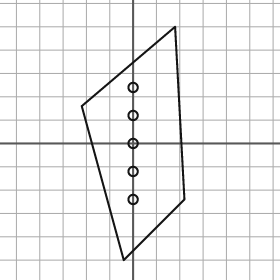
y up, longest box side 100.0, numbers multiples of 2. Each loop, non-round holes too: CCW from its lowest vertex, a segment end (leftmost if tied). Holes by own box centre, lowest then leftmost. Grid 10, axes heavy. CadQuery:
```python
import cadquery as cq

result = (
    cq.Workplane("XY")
    .moveTo(-4.0, -50.0)
    .lineTo(22.0, -24.0)
    .lineTo(18.0, 50.0)
    .lineTo(-22.0, 16.0)
    .close()
    .moveTo(0.0, -24.0)
    .circle(2.0)
    .moveTo(0.0, -12.0)
    .circle(2.0)
    .moveTo(0.0, 0.0)
    .circle(2.0)
    .moveTo(0.0, 12.0)
    .circle(2.0)
    .moveTo(0.0, 24.0)
    .circle(2.0)
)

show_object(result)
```